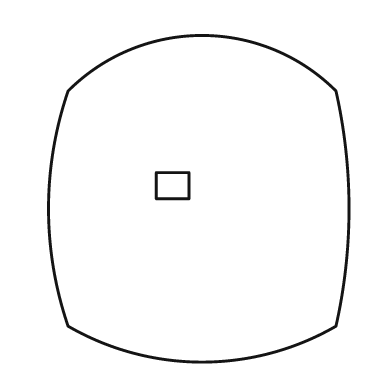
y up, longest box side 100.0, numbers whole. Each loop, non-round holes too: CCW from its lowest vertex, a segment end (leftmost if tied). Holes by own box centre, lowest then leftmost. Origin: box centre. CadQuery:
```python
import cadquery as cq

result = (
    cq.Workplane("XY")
    .moveTo(-40.0, -39.0)
    .threePointArc((1.0, -50.0), (42.0, -39.0))
    .threePointArc((46.0, -3.0), (42.0, 33.0))
    .threePointArc((1.0, 50.0), (-40.0, 33.0))
    .threePointArc((-46.0, -3.0), (-40.0, -39.0))
    .close()
    .moveTo(-13.0, 0.0)
    .lineTo(-3.0, 0.0)
    .lineTo(-3.0, 8.0)
    .lineTo(-13.0, 8.0)
    .close()
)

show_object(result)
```